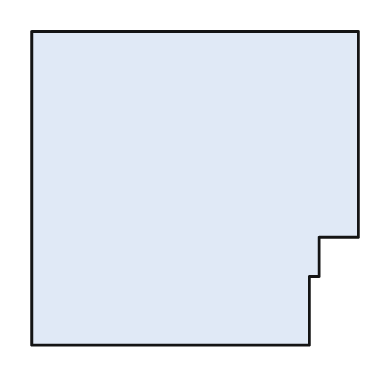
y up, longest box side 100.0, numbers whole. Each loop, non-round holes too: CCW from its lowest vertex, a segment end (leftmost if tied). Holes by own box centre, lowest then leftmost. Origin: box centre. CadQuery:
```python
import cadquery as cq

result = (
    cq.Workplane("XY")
    .moveTo(-50.0, -48.0)
    .lineTo(35.0, -48.0)
    .lineTo(35.0, -27.0)
    .lineTo(38.0, -27.0)
    .lineTo(38.0, -15.0)
    .lineTo(50.0, -15.0)
    .lineTo(50.0, 48.0)
    .lineTo(-50.0, 48.0)
    .close()
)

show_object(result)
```